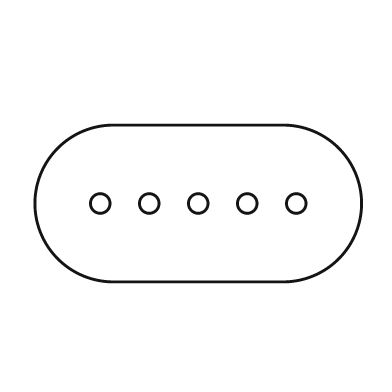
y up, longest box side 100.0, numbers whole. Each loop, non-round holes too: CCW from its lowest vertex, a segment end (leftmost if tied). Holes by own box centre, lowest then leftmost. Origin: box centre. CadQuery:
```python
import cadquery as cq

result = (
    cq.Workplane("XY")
    .moveTo(-26.0, -24.0)
    .lineTo(26.0, -24.0)
    .threePointArc((50.0, 0.0), (26.0, 24.0))
    .lineTo(-26.0, 24.0)
    .threePointArc((-50.0, 0.0), (-26.0, -24.0))
    .close()
    .moveTo(-30.0, 0.0)
    .circle(3.0)
    .moveTo(-15.0, 0.0)
    .circle(3.0)
    .moveTo(0.0, 0.0)
    .circle(3.0)
    .moveTo(15.0, 0.0)
    .circle(3.0)
    .moveTo(30.0, 0.0)
    .circle(3.0)
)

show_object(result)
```